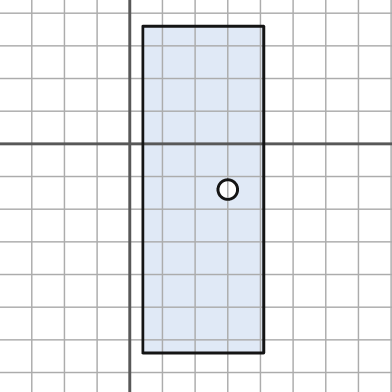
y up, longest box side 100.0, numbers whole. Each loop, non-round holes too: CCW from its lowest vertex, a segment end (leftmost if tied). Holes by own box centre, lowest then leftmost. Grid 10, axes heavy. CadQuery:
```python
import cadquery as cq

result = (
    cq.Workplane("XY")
    .moveTo(4.0, -64.0)
    .lineTo(41.0, -64.0)
    .lineTo(41.0, 36.0)
    .lineTo(4.0, 36.0)
    .close()
    .moveTo(30.0, -14.0)
    .circle(3.0)
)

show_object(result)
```